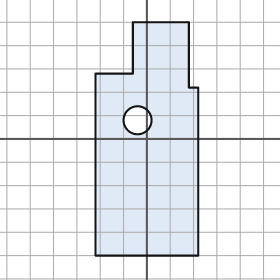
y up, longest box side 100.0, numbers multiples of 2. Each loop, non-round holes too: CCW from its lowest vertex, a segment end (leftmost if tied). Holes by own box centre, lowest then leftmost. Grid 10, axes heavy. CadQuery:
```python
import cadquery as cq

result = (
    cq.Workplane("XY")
    .moveTo(-22.0, -50.0)
    .lineTo(22.0, -50.0)
    .lineTo(22.0, 22.0)
    .lineTo(18.0, 22.0)
    .lineTo(18.0, 50.0)
    .lineTo(-6.0, 50.0)
    .lineTo(-6.0, 28.0)
    .lineTo(-22.0, 28.0)
    .close()
    .moveTo(-4.0, 8.0)
    .circle(6.0)
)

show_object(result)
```